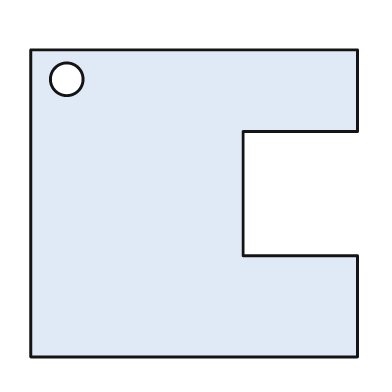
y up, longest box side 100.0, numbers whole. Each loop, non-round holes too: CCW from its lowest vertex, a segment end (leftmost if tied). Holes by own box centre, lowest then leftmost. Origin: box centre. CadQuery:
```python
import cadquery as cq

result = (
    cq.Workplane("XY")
    .moveTo(-50.0, -47.0)
    .lineTo(50.0, -47.0)
    .lineTo(50.0, -16.0)
    .lineTo(15.0, -16.0)
    .lineTo(15.0, 22.0)
    .lineTo(50.0, 22.0)
    .lineTo(50.0, 47.0)
    .lineTo(-50.0, 47.0)
    .close()
    .moveTo(-39.0, 38.0)
    .circle(5.0)
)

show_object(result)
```